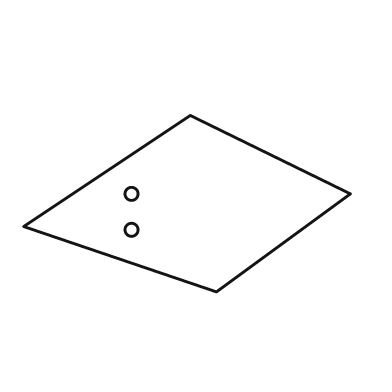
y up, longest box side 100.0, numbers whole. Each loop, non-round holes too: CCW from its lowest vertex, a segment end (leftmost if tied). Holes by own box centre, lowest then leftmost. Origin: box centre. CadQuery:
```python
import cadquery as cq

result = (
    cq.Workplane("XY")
    .moveTo(9.0, -27.0)
    .lineTo(50.0, 3.0)
    .lineTo(1.0, 27.0)
    .lineTo(-50.0, -7.0)
    .close()
    .moveTo(-17.0, -8.0)
    .circle(2.0)
    .moveTo(-17.0, 3.0)
    .circle(2.0)
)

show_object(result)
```